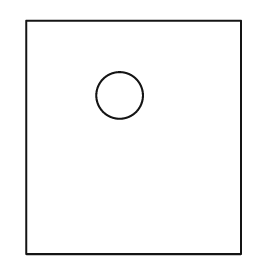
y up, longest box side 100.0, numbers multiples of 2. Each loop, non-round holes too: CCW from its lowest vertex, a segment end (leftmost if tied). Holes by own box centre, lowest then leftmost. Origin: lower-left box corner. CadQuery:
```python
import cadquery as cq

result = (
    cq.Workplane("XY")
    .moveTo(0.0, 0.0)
    .lineTo(92.0, 0.0)
    .lineTo(92.0, 100.0)
    .lineTo(0.0, 100.0)
    .close()
    .moveTo(40.0, 68.0)
    .circle(10.0)
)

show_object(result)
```